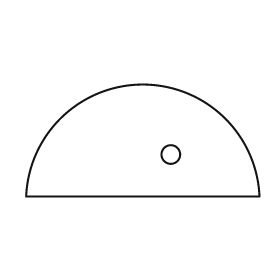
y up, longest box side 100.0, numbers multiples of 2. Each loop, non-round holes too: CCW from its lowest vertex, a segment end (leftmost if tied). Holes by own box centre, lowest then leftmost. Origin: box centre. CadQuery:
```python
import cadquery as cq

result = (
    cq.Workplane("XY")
    .moveTo(-50.0, -24.0)
    .lineTo(50.0, -24.0)
    .threePointArc((0.0, 24.0), (-50.0, -24.0))
    .close()
    .moveTo(12.0, -6.0)
    .circle(4.0)
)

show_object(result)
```